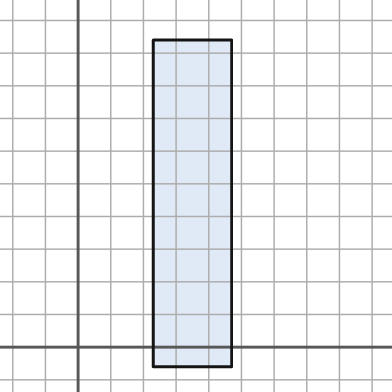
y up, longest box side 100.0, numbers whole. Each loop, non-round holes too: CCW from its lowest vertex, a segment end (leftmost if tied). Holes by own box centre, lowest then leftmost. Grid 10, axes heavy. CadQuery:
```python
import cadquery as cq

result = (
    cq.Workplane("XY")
    .moveTo(23.0, -6.0)
    .lineTo(47.0, -6.0)
    .lineTo(47.0, 94.0)
    .lineTo(23.0, 94.0)
    .close()
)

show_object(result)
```